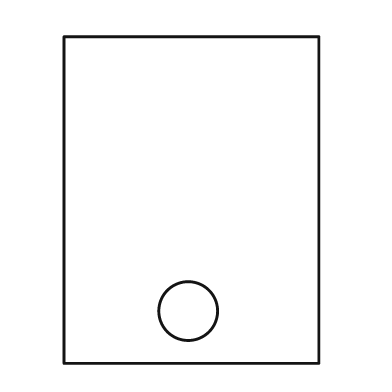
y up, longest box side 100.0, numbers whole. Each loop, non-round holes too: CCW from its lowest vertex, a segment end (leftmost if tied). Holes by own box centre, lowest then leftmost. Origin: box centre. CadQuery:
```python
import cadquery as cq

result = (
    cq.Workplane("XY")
    .moveTo(-39.0, -50.0)
    .lineTo(39.0, -50.0)
    .lineTo(39.0, 50.0)
    .lineTo(-39.0, 50.0)
    .close()
    .moveTo(-1.0, -34.0)
    .circle(9.0)
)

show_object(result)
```